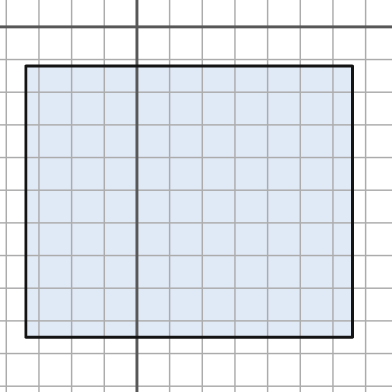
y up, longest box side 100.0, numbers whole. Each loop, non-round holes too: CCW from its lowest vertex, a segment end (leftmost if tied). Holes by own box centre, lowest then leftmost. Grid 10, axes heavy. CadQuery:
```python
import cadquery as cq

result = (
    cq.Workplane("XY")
    .moveTo(-34.0, -95.0)
    .lineTo(66.0, -95.0)
    .lineTo(66.0, -12.0)
    .lineTo(-34.0, -12.0)
    .close()
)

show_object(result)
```